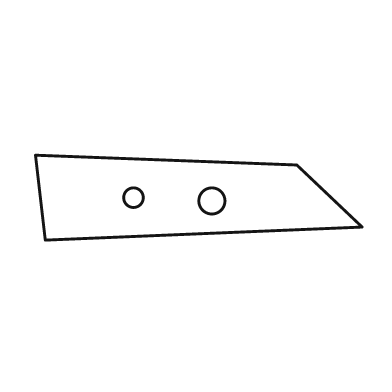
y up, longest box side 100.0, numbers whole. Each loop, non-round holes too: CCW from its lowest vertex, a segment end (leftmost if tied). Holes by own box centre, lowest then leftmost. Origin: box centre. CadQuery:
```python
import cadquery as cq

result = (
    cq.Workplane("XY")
    .moveTo(-47.0, -13.0)
    .lineTo(50.0, -9.0)
    .lineTo(30.0, 10.0)
    .lineTo(-50.0, 13.0)
    .close()
    .moveTo(4.0, -1.0)
    .circle(4.0)
    .moveTo(-20.0, 0.0)
    .circle(3.0)
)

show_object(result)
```